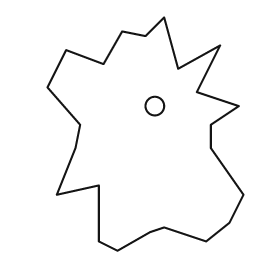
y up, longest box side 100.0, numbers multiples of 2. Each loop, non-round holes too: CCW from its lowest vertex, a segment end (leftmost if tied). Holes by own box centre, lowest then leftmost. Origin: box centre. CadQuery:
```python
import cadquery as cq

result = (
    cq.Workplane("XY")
    .moveTo(-12.0, -50.0)
    .lineTo(2.0, -42.0)
    .lineTo(8.0, -40.0)
    .lineTo(26.0, -46.0)
    .lineTo(36.0, -38.0)
    .lineTo(42.0, -26.0)
    .lineTo(28.0, -6.0)
    .lineTo(28.0, 4.0)
    .lineTo(40.0, 12.0)
    .lineTo(22.0, 18.0)
    .lineTo(32.0, 38.0)
    .lineTo(14.0, 28.0)
    .lineTo(8.0, 50.0)
    .lineTo(0.0, 42.0)
    .lineTo(-10.0, 44.0)
    .lineTo(-18.0, 30.0)
    .lineTo(-34.0, 36.0)
    .lineTo(-42.0, 20.0)
    .lineTo(-28.0, 4.0)
    .lineTo(-30.0, -6.0)
    .lineTo(-38.0, -26.0)
    .lineTo(-20.0, -22.0)
    .lineTo(-20.0, -46.0)
    .close()
    .moveTo(4.0, 12.0)
    .circle(4.0)
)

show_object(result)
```